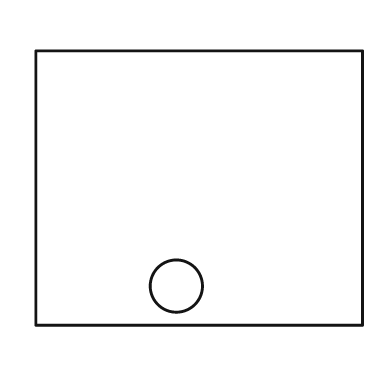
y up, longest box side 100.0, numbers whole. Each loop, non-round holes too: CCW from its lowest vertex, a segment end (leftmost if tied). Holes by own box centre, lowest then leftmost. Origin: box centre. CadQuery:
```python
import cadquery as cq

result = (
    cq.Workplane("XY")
    .moveTo(-50.0, -42.0)
    .lineTo(50.0, -42.0)
    .lineTo(50.0, 42.0)
    .lineTo(-50.0, 42.0)
    .close()
    .moveTo(-7.0, -30.0)
    .circle(8.0)
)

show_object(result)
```